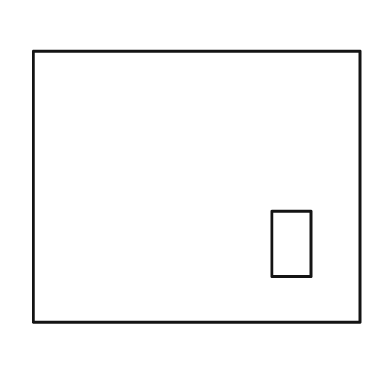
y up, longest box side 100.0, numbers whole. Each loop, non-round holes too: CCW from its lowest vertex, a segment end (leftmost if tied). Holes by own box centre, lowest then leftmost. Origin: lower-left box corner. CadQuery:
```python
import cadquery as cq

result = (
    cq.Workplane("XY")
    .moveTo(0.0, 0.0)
    .lineTo(100.0, 0.0)
    .lineTo(100.0, 83.0)
    .lineTo(0.0, 83.0)
    .close()
    .moveTo(73.0, 14.0)
    .lineTo(85.0, 14.0)
    .lineTo(85.0, 34.0)
    .lineTo(73.0, 34.0)
    .close()
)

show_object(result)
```